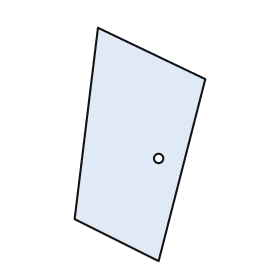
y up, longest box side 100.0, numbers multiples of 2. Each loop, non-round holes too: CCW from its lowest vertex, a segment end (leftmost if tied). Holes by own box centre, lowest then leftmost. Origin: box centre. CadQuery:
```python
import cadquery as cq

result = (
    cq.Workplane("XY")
    .moveTo(8.0, -50.0)
    .lineTo(28.0, 28.0)
    .lineTo(-18.0, 50.0)
    .lineTo(-28.0, -32.0)
    .close()
    .moveTo(8.0, -6.0)
    .circle(2.0)
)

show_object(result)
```